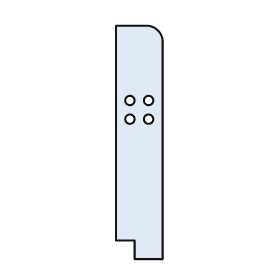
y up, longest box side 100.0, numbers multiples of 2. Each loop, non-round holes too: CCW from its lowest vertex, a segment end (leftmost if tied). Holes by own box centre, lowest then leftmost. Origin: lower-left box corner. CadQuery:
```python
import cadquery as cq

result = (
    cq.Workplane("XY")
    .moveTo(8.0, 0.0)
    .lineTo(20.0, 0.0)
    .lineTo(20.0, 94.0)
    .threePointArc((18.0, 98.0), (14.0, 100.0))
    .lineTo(0.0, 100.0)
    .lineTo(0.0, 8.0)
    .lineTo(8.0, 8.0)
    .close()
    .moveTo(6.0, 60.0)
    .circle(2.0)
    .moveTo(14.0, 60.0)
    .circle(2.0)
    .moveTo(6.0, 68.0)
    .circle(2.0)
    .moveTo(14.0, 68.0)
    .circle(2.0)
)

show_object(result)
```